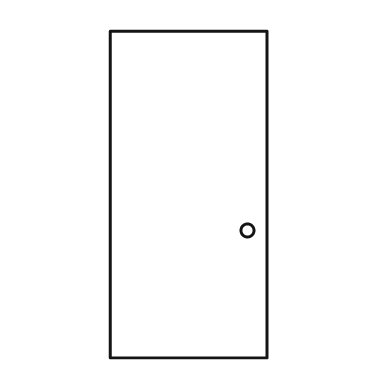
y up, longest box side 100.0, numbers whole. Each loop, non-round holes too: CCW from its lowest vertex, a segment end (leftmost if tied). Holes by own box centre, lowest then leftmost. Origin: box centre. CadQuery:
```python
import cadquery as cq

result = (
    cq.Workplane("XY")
    .moveTo(-24.0, -50.0)
    .lineTo(24.0, -50.0)
    .lineTo(24.0, 50.0)
    .lineTo(-24.0, 50.0)
    .close()
    .moveTo(18.0, -11.0)
    .circle(2.0)
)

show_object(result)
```